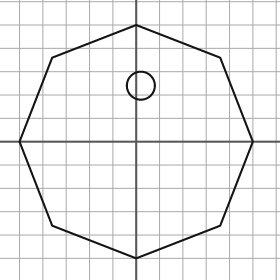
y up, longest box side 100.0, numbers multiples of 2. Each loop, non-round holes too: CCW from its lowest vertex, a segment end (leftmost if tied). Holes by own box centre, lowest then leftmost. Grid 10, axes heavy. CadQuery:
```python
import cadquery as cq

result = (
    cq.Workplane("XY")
    .moveTo(0.0, -50.0)
    .lineTo(36.0, -36.0)
    .lineTo(50.0, 0.0)
    .lineTo(36.0, 36.0)
    .lineTo(0.0, 50.0)
    .lineTo(-36.0, 36.0)
    .lineTo(-50.0, 0.0)
    .lineTo(-36.0, -36.0)
    .close()
    .moveTo(2.0, 24.0)
    .circle(6.0)
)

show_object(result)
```